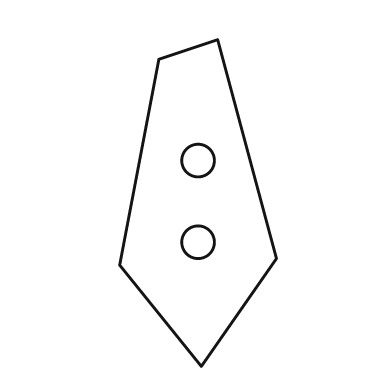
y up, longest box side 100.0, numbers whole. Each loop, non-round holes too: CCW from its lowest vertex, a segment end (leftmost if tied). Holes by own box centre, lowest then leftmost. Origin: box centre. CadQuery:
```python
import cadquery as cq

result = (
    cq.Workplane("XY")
    .moveTo(1.0, -50.0)
    .lineTo(24.0, -17.0)
    .lineTo(6.0, 50.0)
    .lineTo(-12.0, 44.0)
    .lineTo(-24.0, -19.0)
    .close()
    .moveTo(0.0, -12.0)
    .circle(5.0)
    .moveTo(0.0, 13.0)
    .circle(5.0)
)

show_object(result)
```